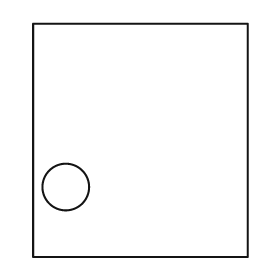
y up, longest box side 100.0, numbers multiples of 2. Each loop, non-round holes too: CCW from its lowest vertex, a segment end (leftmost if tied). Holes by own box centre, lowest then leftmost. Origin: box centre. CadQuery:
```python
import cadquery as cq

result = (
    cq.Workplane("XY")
    .moveTo(-46.0, -50.0)
    .lineTo(46.0, -50.0)
    .lineTo(46.0, 50.0)
    .lineTo(-46.0, 50.0)
    .close()
    .moveTo(-32.0, -20.0)
    .circle(10.0)
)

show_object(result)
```